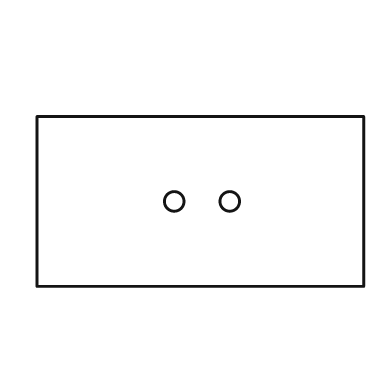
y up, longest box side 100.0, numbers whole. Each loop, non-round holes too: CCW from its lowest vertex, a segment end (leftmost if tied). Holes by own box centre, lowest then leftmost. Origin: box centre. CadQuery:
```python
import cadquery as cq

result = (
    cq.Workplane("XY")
    .moveTo(-50.0, -26.0)
    .lineTo(50.0, -26.0)
    .lineTo(50.0, 26.0)
    .lineTo(-50.0, 26.0)
    .close()
    .moveTo(-8.0, 0.0)
    .circle(3.0)
    .moveTo(9.0, 0.0)
    .circle(3.0)
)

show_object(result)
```